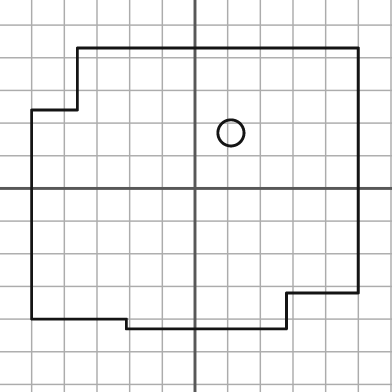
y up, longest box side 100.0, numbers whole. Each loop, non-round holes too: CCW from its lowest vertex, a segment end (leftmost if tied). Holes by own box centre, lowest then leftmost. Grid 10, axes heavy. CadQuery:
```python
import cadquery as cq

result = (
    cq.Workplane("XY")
    .moveTo(-21.0, -43.0)
    .lineTo(28.0, -43.0)
    .lineTo(28.0, -32.0)
    .lineTo(50.0, -32.0)
    .lineTo(50.0, 43.0)
    .lineTo(-36.0, 43.0)
    .lineTo(-36.0, 24.0)
    .lineTo(-50.0, 24.0)
    .lineTo(-50.0, -40.0)
    .lineTo(-21.0, -40.0)
    .close()
    .moveTo(11.0, 17.0)
    .circle(4.0)
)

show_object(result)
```